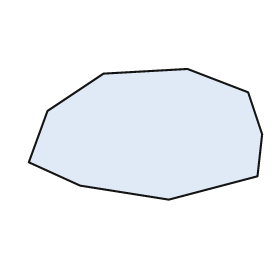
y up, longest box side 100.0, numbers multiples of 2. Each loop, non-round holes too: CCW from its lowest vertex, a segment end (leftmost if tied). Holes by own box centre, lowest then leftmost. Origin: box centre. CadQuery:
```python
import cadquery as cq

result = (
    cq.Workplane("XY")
    .moveTo(10.0, -28.0)
    .lineTo(48.0, -18.0)
    .lineTo(50.0, 0.0)
    .lineTo(44.0, 18.0)
    .lineTo(18.0, 28.0)
    .lineTo(-18.0, 26.0)
    .lineTo(-42.0, 10.0)
    .lineTo(-50.0, -12.0)
    .lineTo(-28.0, -22.0)
    .close()
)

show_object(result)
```